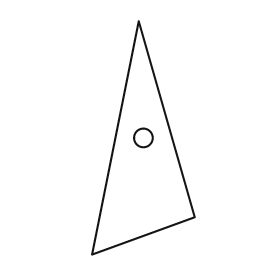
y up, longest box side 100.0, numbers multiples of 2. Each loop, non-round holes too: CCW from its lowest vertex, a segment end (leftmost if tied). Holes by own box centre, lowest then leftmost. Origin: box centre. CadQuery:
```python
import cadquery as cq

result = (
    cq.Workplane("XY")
    .moveTo(-22.0, -50.0)
    .lineTo(22.0, -34.0)
    .lineTo(-2.0, 50.0)
    .close()
    .moveTo(0.0, 0.0)
    .circle(4.0)
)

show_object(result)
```